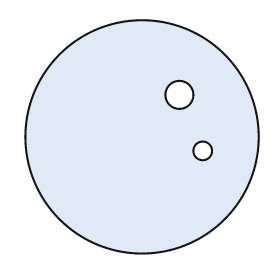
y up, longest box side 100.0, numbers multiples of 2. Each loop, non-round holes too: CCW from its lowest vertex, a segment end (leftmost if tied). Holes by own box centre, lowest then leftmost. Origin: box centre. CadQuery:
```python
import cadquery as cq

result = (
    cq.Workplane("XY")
    .moveTo(0.0, 0.0)
    .circle(50.0)
    .moveTo(26.0, -6.0)
    .circle(4.0)
    .moveTo(16.0, 18.0)
    .circle(6.0)
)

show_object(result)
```